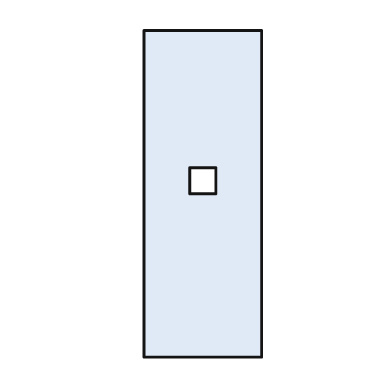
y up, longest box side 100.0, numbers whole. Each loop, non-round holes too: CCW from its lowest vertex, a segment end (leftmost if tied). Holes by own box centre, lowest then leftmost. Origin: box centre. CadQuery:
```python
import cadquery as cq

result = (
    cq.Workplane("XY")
    .moveTo(-18.0, -50.0)
    .lineTo(18.0, -50.0)
    .lineTo(18.0, 50.0)
    .lineTo(-18.0, 50.0)
    .close()
    .moveTo(-4.0, 0.0)
    .lineTo(4.0, 0.0)
    .lineTo(4.0, 8.0)
    .lineTo(-4.0, 8.0)
    .close()
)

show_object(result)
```